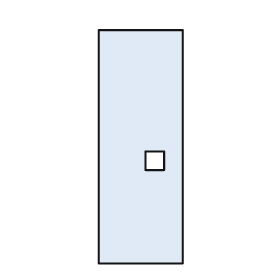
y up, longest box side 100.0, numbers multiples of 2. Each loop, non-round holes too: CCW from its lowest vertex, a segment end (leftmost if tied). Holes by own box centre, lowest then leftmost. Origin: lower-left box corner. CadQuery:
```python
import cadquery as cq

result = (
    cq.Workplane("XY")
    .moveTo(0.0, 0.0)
    .lineTo(36.0, 0.0)
    .lineTo(36.0, 100.0)
    .lineTo(0.0, 100.0)
    .close()
    .moveTo(20.0, 40.0)
    .lineTo(28.0, 40.0)
    .lineTo(28.0, 48.0)
    .lineTo(20.0, 48.0)
    .close()
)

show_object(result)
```